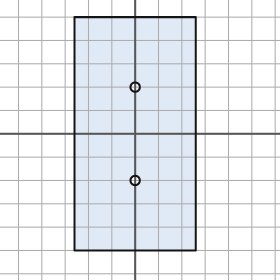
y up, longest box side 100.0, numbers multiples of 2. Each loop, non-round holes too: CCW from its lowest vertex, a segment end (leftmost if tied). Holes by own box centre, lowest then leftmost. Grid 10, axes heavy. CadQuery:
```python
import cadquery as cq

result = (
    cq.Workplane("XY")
    .moveTo(-26.0, -50.0)
    .lineTo(26.0, -50.0)
    .lineTo(26.0, 50.0)
    .lineTo(-26.0, 50.0)
    .close()
    .moveTo(0.0, -20.0)
    .circle(2.0)
    .moveTo(0.0, 20.0)
    .circle(2.0)
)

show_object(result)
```